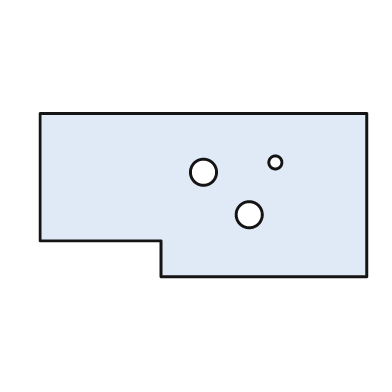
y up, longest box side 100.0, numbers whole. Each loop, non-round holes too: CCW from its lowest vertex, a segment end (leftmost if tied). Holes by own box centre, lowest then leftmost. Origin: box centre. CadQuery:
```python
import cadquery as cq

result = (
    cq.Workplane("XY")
    .moveTo(-13.0, -25.0)
    .lineTo(50.0, -25.0)
    .lineTo(50.0, 25.0)
    .lineTo(-50.0, 25.0)
    .lineTo(-50.0, -14.0)
    .lineTo(-13.0, -14.0)
    .close()
    .moveTo(14.0, -6.0)
    .circle(4.0)
    .moveTo(0.0, 7.0)
    .circle(4.0)
    .moveTo(22.0, 10.0)
    .circle(2.0)
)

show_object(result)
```